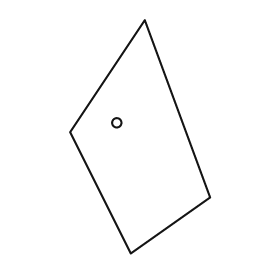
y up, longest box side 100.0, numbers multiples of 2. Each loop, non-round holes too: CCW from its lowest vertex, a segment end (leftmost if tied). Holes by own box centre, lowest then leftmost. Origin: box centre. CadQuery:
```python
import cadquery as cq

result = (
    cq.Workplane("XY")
    .moveTo(-4.0, -50.0)
    .lineTo(30.0, -26.0)
    .lineTo(2.0, 50.0)
    .lineTo(-30.0, 2.0)
    .close()
    .moveTo(-10.0, 6.0)
    .circle(2.0)
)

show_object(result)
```